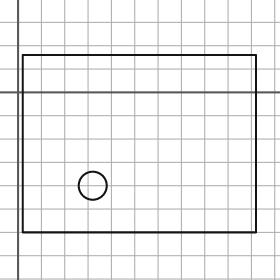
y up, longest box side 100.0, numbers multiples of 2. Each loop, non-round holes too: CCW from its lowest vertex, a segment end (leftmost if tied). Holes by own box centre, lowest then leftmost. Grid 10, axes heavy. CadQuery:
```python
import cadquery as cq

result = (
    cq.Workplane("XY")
    .moveTo(2.0, -60.0)
    .lineTo(102.0, -60.0)
    .lineTo(102.0, 16.0)
    .lineTo(2.0, 16.0)
    .close()
    .moveTo(32.0, -40.0)
    .circle(6.0)
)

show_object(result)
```